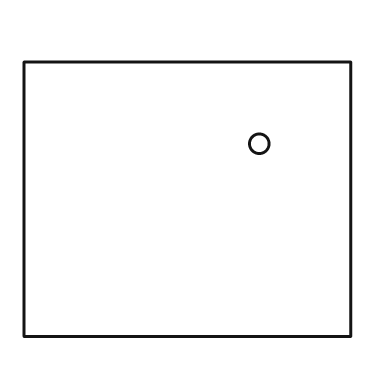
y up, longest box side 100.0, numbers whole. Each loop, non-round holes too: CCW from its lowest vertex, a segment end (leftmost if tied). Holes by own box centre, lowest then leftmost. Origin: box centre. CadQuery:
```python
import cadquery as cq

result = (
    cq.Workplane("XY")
    .moveTo(-50.0, -42.0)
    .lineTo(50.0, -42.0)
    .lineTo(50.0, 42.0)
    .lineTo(-50.0, 42.0)
    .close()
    .moveTo(22.0, 17.0)
    .circle(3.0)
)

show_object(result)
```